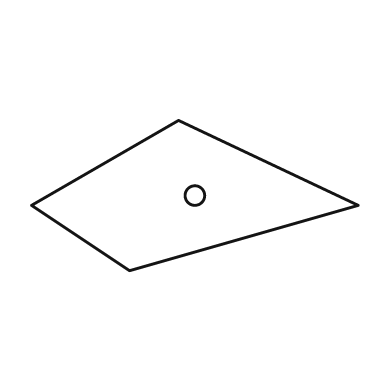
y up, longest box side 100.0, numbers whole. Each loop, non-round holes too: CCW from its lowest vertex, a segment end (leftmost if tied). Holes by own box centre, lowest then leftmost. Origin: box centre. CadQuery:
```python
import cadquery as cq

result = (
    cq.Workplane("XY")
    .moveTo(-20.0, -23.0)
    .lineTo(50.0, -3.0)
    .lineTo(-5.0, 23.0)
    .lineTo(-50.0, -3.0)
    .close()
    .moveTo(0.0, 0.0)
    .circle(3.0)
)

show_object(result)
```